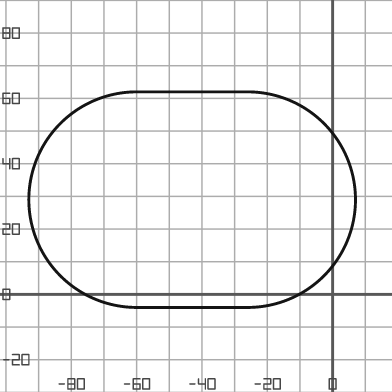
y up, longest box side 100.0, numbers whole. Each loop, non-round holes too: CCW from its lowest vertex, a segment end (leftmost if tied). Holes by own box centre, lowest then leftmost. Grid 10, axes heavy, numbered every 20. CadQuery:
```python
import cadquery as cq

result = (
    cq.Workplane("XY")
    .moveTo(-60.0, -4.0)
    .lineTo(-26.0, -4.0)
    .threePointArc((7.0, 29.0), (-26.0, 62.0))
    .lineTo(-60.0, 62.0)
    .threePointArc((-93.0, 29.0), (-60.0, -4.0))
    .close()
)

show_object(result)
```